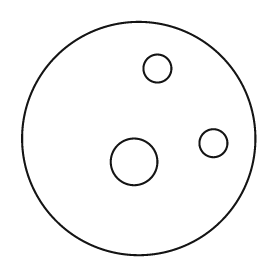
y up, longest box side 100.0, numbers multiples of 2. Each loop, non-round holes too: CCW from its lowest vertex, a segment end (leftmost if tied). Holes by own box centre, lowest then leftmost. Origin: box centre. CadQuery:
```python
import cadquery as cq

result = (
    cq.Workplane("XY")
    .moveTo(0.0, 0.0)
    .circle(50.0)
    .moveTo(-2.0, -10.0)
    .circle(10.0)
    .moveTo(32.0, -2.0)
    .circle(6.0)
    .moveTo(8.0, 30.0)
    .circle(6.0)
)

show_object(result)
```